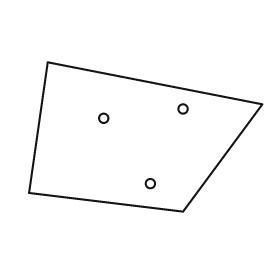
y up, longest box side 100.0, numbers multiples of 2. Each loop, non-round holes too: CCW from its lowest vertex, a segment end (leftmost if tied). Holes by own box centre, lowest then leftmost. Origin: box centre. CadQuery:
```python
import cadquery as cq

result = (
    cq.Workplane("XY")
    .moveTo(16.0, -32.0)
    .lineTo(50.0, 14.0)
    .lineTo(-42.0, 32.0)
    .lineTo(-50.0, -24.0)
    .close()
    .moveTo(2.0, -20.0)
    .circle(2.0)
    .moveTo(-18.0, 8.0)
    .circle(2.0)
    .moveTo(16.0, 12.0)
    .circle(2.0)
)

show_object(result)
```